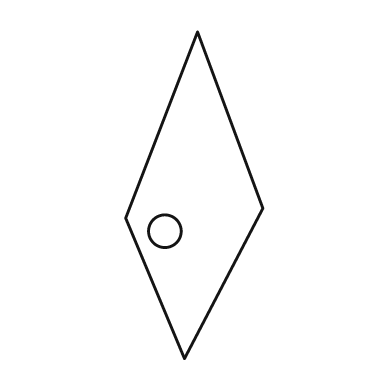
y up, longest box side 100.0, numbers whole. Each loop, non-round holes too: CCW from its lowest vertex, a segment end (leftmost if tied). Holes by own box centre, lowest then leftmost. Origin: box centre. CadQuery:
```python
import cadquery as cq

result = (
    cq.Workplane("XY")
    .moveTo(-3.0, -50.0)
    .lineTo(21.0, -4.0)
    .lineTo(1.0, 50.0)
    .lineTo(-21.0, -7.0)
    .close()
    .moveTo(-9.0, -11.0)
    .circle(5.0)
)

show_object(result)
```